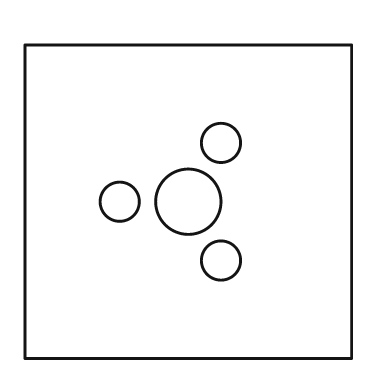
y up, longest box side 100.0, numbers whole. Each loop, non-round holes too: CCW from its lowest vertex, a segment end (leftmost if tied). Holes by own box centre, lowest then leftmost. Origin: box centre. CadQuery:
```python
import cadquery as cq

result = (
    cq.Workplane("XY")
    .moveTo(-50.0, -48.0)
    .lineTo(50.0, -48.0)
    .lineTo(50.0, 48.0)
    .lineTo(-50.0, 48.0)
    .close()
    .moveTo(10.0, -18.0)
    .circle(6.0)
    .moveTo(-21.0, 0.0)
    .circle(6.0)
    .moveTo(0.0, 0.0)
    .circle(10.0)
    .moveTo(10.0, 18.0)
    .circle(6.0)
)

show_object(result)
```